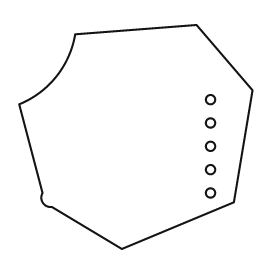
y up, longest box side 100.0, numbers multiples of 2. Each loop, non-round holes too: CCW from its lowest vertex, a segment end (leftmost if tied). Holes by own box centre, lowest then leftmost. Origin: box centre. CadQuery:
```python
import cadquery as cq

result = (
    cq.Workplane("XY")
    .moveTo(-6.0, -48.0)
    .lineTo(42.0, -28.0)
    .lineTo(50.0, 20.0)
    .lineTo(26.0, 48.0)
    .lineTo(-26.0, 44.0)
    .threePointArc((-34.0, 26.0), (-50.0, 14.0))
    .lineTo(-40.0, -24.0)
    .threePointArc((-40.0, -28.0), (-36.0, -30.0))
    .close()
    .moveTo(32.0, -24.0)
    .circle(2.0)
    .moveTo(32.0, -14.0)
    .circle(2.0)
    .moveTo(32.0, -4.0)
    .circle(2.0)
    .moveTo(32.0, 6.0)
    .circle(2.0)
    .moveTo(32.0, 16.0)
    .circle(2.0)
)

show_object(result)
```